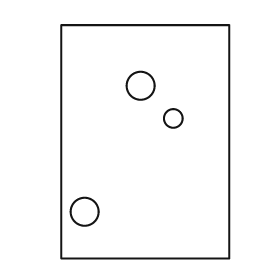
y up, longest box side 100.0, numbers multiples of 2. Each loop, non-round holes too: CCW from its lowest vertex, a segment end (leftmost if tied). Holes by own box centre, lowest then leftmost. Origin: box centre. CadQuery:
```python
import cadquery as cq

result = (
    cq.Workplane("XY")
    .moveTo(-36.0, -50.0)
    .lineTo(36.0, -50.0)
    .lineTo(36.0, 50.0)
    .lineTo(-36.0, 50.0)
    .close()
    .moveTo(-26.0, -30.0)
    .circle(6.0)
    .moveTo(12.0, 10.0)
    .circle(4.0)
    .moveTo(-2.0, 24.0)
    .circle(6.0)
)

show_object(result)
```